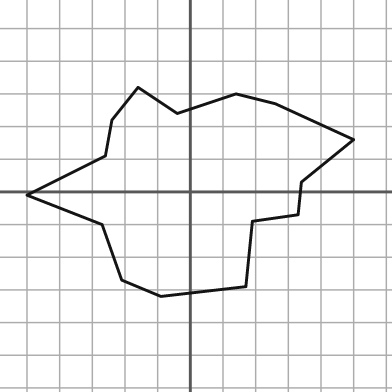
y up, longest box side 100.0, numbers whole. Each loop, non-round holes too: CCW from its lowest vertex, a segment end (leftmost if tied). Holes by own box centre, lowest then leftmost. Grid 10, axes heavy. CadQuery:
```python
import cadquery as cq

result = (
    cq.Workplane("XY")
    .moveTo(-9.0, -32.0)
    .lineTo(17.0, -29.0)
    .lineTo(19.0, -9.0)
    .lineTo(33.0, -7.0)
    .lineTo(34.0, 3.0)
    .lineTo(50.0, 16.0)
    .lineTo(26.0, 27.0)
    .lineTo(14.0, 30.0)
    .lineTo(-4.0, 24.0)
    .lineTo(-16.0, 32.0)
    .lineTo(-24.0, 22.0)
    .lineTo(-26.0, 11.0)
    .lineTo(-50.0, -1.0)
    .lineTo(-27.0, -10.0)
    .lineTo(-21.0, -27.0)
    .close()
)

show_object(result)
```